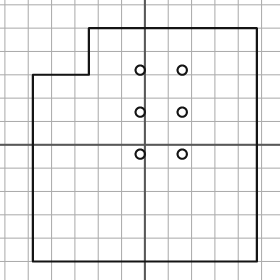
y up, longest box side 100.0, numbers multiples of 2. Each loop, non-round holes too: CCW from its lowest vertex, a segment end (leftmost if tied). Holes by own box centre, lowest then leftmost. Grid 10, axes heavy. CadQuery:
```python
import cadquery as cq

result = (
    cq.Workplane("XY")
    .moveTo(-48.0, -50.0)
    .lineTo(48.0, -50.0)
    .lineTo(48.0, 50.0)
    .lineTo(-24.0, 50.0)
    .lineTo(-24.0, 30.0)
    .lineTo(-48.0, 30.0)
    .close()
    .moveTo(-2.0, -4.0)
    .circle(2.0)
    .moveTo(16.0, -4.0)
    .circle(2.0)
    .moveTo(-2.0, 14.0)
    .circle(2.0)
    .moveTo(16.0, 14.0)
    .circle(2.0)
    .moveTo(-2.0, 32.0)
    .circle(2.0)
    .moveTo(16.0, 32.0)
    .circle(2.0)
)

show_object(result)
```